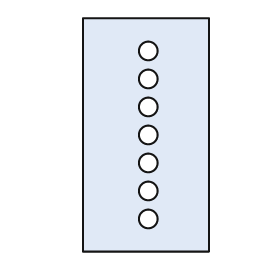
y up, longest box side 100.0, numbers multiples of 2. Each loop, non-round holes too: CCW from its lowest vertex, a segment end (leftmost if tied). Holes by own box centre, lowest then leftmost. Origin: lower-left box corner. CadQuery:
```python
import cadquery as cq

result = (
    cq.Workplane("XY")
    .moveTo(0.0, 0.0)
    .lineTo(54.0, 0.0)
    .lineTo(54.0, 100.0)
    .lineTo(0.0, 100.0)
    .close()
    .moveTo(28.0, 14.0)
    .circle(4.0)
    .moveTo(28.0, 26.0)
    .circle(4.0)
    .moveTo(28.0, 38.0)
    .circle(4.0)
    .moveTo(28.0, 50.0)
    .circle(4.0)
    .moveTo(28.0, 62.0)
    .circle(4.0)
    .moveTo(28.0, 74.0)
    .circle(4.0)
    .moveTo(28.0, 86.0)
    .circle(4.0)
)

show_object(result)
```